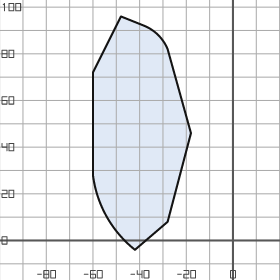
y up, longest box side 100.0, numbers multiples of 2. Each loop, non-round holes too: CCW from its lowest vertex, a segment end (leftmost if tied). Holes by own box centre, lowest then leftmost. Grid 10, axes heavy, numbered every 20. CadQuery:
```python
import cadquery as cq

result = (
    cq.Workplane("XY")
    .moveTo(-42.0, -4.0)
    .lineTo(-28.0, 8.0)
    .lineTo(-18.0, 46.0)
    .lineTo(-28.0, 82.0)
    .threePointArc((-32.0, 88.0), (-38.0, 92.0))
    .lineTo(-48.0, 96.0)
    .lineTo(-60.0, 72.0)
    .lineTo(-60.0, 28.0)
    .threePointArc((-54.0, 10.0), (-42.0, -4.0))
    .close()
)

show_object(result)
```